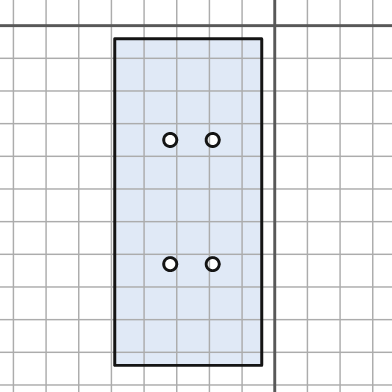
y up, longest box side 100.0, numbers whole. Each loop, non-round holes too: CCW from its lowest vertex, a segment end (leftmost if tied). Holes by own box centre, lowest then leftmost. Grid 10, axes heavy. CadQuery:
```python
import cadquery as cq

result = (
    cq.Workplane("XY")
    .moveTo(-49.0, -104.0)
    .lineTo(-4.0, -104.0)
    .lineTo(-4.0, -4.0)
    .lineTo(-49.0, -4.0)
    .close()
    .moveTo(-32.0, -73.0)
    .circle(2.0)
    .moveTo(-19.0, -73.0)
    .circle(2.0)
    .moveTo(-32.0, -35.0)
    .circle(2.0)
    .moveTo(-19.0, -35.0)
    .circle(2.0)
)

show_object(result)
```